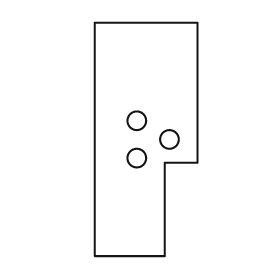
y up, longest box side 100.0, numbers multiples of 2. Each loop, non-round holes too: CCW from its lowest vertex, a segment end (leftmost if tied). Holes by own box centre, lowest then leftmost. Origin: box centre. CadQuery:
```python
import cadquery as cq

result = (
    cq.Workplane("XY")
    .moveTo(-22.0, -50.0)
    .lineTo(8.0, -50.0)
    .lineTo(8.0, -10.0)
    .lineTo(22.0, -10.0)
    .lineTo(22.0, 50.0)
    .lineTo(-22.0, 50.0)
    .close()
    .moveTo(-4.0, -8.0)
    .circle(4.0)
    .moveTo(10.0, 0.0)
    .circle(4.0)
    .moveTo(-4.0, 8.0)
    .circle(4.0)
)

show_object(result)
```